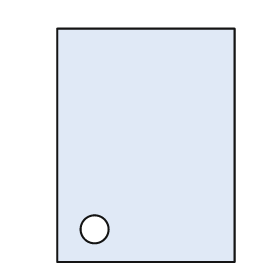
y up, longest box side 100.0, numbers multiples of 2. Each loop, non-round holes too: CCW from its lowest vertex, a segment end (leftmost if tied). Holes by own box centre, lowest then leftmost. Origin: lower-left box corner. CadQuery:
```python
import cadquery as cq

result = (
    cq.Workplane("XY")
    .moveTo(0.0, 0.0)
    .lineTo(76.0, 0.0)
    .lineTo(76.0, 100.0)
    .lineTo(0.0, 100.0)
    .close()
    .moveTo(16.0, 14.0)
    .circle(6.0)
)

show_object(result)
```